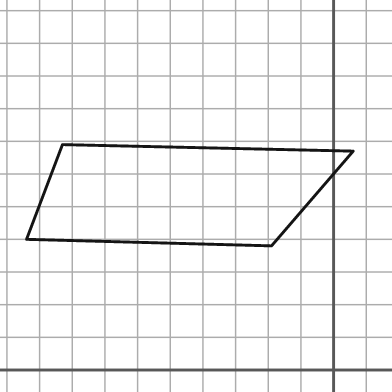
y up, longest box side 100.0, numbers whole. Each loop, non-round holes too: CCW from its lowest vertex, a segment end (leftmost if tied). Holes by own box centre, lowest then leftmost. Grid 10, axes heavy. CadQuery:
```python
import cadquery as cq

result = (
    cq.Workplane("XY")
    .moveTo(-19.0, 38.0)
    .lineTo(6.0, 67.0)
    .lineTo(-83.0, 69.0)
    .lineTo(-94.0, 40.0)
    .close()
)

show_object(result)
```